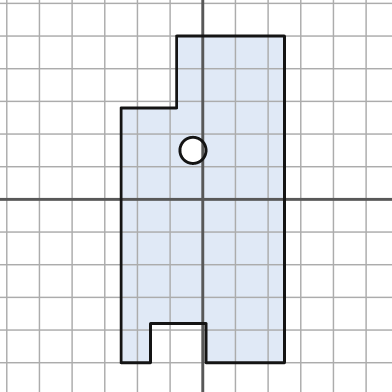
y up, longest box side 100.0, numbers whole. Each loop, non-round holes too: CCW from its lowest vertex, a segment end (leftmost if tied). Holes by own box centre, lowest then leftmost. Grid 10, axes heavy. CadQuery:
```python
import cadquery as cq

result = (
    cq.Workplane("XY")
    .moveTo(-25.0, -50.0)
    .lineTo(-16.0, -50.0)
    .lineTo(-16.0, -38.0)
    .lineTo(1.0, -38.0)
    .lineTo(1.0, -50.0)
    .lineTo(25.0, -50.0)
    .lineTo(25.0, 50.0)
    .lineTo(-8.0, 50.0)
    .lineTo(-8.0, 28.0)
    .lineTo(-25.0, 28.0)
    .close()
    .moveTo(-3.0, 15.0)
    .circle(4.0)
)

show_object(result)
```